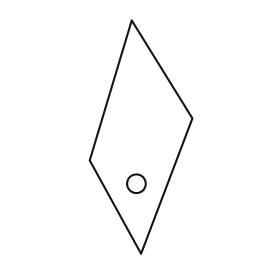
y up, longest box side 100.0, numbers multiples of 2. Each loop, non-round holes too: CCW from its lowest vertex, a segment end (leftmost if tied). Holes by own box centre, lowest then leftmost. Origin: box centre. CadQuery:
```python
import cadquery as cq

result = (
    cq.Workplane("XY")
    .moveTo(0.0, -50.0)
    .lineTo(22.0, 8.0)
    .lineTo(-4.0, 50.0)
    .lineTo(-22.0, -10.0)
    .close()
    .moveTo(-2.0, -20.0)
    .circle(4.0)
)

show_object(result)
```